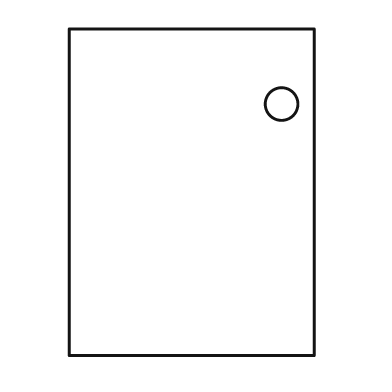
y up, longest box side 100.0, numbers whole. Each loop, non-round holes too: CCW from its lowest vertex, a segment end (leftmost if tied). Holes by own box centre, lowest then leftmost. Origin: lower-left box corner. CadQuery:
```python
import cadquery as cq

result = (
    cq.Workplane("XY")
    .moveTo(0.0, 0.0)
    .lineTo(75.0, 0.0)
    .lineTo(75.0, 100.0)
    .lineTo(0.0, 100.0)
    .close()
    .moveTo(65.0, 77.0)
    .circle(5.0)
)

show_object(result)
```